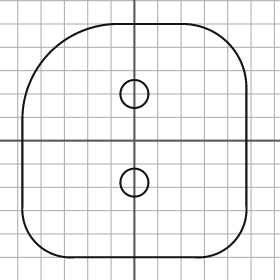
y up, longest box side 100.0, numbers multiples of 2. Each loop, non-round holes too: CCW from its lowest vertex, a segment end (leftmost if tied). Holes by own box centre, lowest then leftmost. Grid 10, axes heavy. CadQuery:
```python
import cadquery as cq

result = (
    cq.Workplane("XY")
    .moveTo(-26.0, -50.0)
    .lineTo(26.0, -50.0)
    .threePointArc((42.0, -44.0), (48.0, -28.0))
    .lineTo(48.0, 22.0)
    .threePointArc((40.0, 42.0), (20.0, 50.0))
    .lineTo(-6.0, 50.0)
    .threePointArc((-36.0, 38.0), (-48.0, 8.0))
    .lineTo(-48.0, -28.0)
    .threePointArc((-42.0, -44.0), (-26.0, -50.0))
    .close()
    .moveTo(0.0, -18.0)
    .circle(6.0)
    .moveTo(0.0, 20.0)
    .circle(6.0)
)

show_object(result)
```